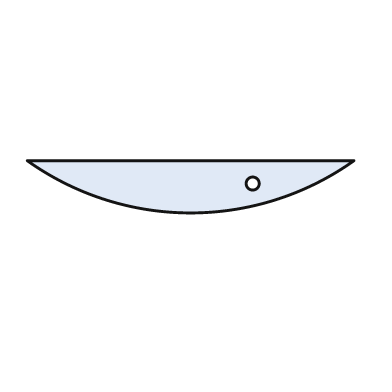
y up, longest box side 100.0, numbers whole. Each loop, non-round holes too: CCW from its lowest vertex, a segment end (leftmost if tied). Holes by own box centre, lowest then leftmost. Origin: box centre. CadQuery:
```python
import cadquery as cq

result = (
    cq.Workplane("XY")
    .moveTo(-50.0, 8.0)
    .threePointArc((0.0, -8.0), (50.0, 8.0))
    .close()
    .moveTo(19.0, 1.0)
    .circle(2.0)
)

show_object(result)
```